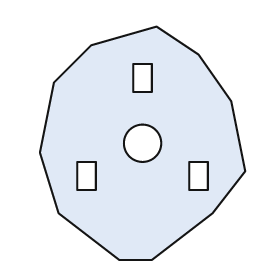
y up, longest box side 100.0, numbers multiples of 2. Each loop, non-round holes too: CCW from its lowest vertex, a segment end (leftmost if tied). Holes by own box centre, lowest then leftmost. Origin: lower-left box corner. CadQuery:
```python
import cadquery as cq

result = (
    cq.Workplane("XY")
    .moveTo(34.0, 0.0)
    .lineTo(48.0, 0.0)
    .lineTo(74.0, 20.0)
    .lineTo(88.0, 38.0)
    .lineTo(82.0, 68.0)
    .lineTo(68.0, 88.0)
    .lineTo(50.0, 100.0)
    .lineTo(22.0, 92.0)
    .lineTo(6.0, 76.0)
    .lineTo(0.0, 46.0)
    .lineTo(8.0, 20.0)
    .close()
    .moveTo(16.0, 30.0)
    .lineTo(24.0, 30.0)
    .lineTo(24.0, 42.0)
    .lineTo(16.0, 42.0)
    .close()
    .moveTo(64.0, 30.0)
    .lineTo(72.0, 30.0)
    .lineTo(72.0, 42.0)
    .lineTo(64.0, 42.0)
    .close()
    .moveTo(44.0, 50.0)
    .circle(8.0)
    .moveTo(40.0, 72.0)
    .lineTo(48.0, 72.0)
    .lineTo(48.0, 84.0)
    .lineTo(40.0, 84.0)
    .close()
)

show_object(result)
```